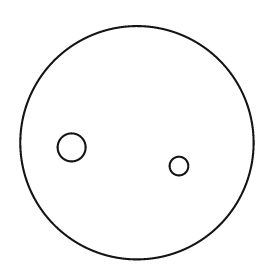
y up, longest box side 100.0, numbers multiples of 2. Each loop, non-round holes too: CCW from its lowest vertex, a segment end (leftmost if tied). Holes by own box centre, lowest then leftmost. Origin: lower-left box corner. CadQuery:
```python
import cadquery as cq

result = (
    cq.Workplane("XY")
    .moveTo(50.0, 50.0)
    .circle(50.0)
    .moveTo(68.0, 40.0)
    .circle(4.0)
    .moveTo(22.0, 48.0)
    .circle(6.0)
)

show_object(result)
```